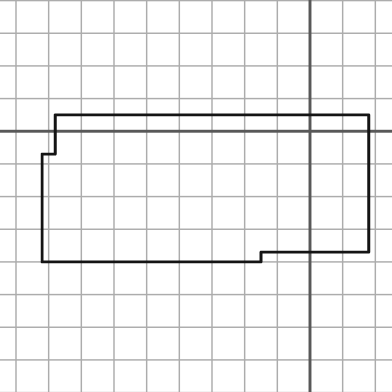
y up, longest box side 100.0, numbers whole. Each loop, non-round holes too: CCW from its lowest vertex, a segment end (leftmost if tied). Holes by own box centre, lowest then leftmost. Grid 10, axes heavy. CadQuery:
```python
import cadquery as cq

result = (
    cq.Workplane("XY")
    .moveTo(-82.0, -40.0)
    .lineTo(-15.0, -40.0)
    .lineTo(-15.0, -37.0)
    .lineTo(18.0, -37.0)
    .lineTo(18.0, 5.0)
    .lineTo(-78.0, 5.0)
    .lineTo(-78.0, -7.0)
    .lineTo(-82.0, -7.0)
    .close()
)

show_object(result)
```